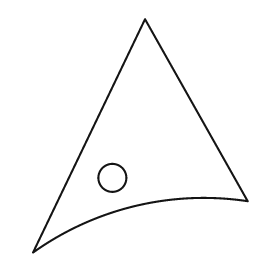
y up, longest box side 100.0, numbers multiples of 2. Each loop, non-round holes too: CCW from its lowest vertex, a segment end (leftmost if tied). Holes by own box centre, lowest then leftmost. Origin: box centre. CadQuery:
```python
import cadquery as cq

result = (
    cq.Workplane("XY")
    .moveTo(-46.0, -50.0)
    .threePointArc((-2.0, -30.0), (46.0, -28.0))
    .lineTo(2.0, 50.0)
    .close()
    .moveTo(-12.0, -18.0)
    .circle(6.0)
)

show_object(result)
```